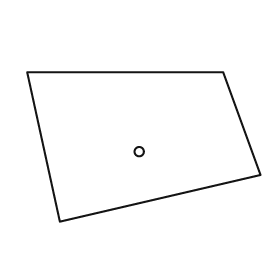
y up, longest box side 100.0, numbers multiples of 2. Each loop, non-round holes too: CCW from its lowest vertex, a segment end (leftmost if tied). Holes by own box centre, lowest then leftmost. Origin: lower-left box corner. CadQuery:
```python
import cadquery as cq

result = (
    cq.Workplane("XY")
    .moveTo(14.0, 0.0)
    .lineTo(100.0, 20.0)
    .lineTo(84.0, 64.0)
    .lineTo(0.0, 64.0)
    .close()
    .moveTo(48.0, 30.0)
    .circle(2.0)
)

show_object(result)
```